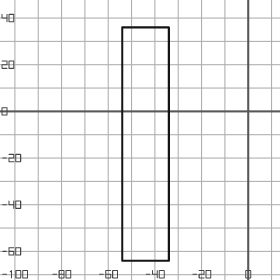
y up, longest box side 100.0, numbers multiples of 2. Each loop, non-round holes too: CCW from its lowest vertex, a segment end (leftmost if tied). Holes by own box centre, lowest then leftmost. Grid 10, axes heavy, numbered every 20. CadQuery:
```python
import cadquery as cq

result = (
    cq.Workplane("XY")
    .moveTo(-54.0, -64.0)
    .lineTo(-34.0, -64.0)
    .lineTo(-34.0, 36.0)
    .lineTo(-54.0, 36.0)
    .close()
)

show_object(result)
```